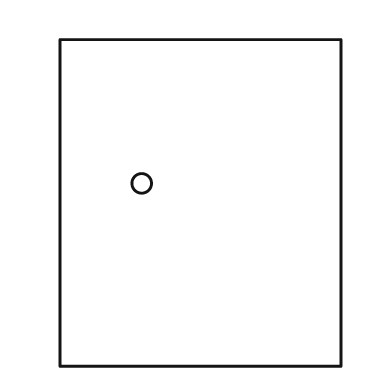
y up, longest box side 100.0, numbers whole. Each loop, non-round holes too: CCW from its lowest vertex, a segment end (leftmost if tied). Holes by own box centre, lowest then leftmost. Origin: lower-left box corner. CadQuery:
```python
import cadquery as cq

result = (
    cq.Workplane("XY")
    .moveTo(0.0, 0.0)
    .lineTo(86.0, 0.0)
    .lineTo(86.0, 100.0)
    .lineTo(0.0, 100.0)
    .close()
    .moveTo(25.0, 56.0)
    .circle(3.0)
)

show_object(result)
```